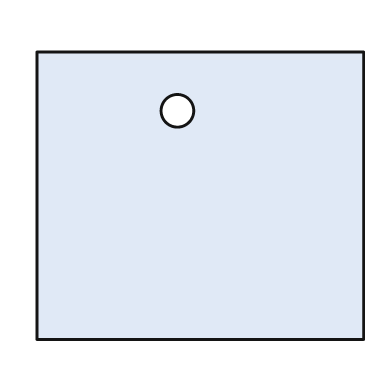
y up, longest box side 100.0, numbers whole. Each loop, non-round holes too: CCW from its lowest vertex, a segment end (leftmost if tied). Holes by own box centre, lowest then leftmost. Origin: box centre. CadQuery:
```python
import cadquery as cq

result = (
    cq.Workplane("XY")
    .moveTo(-50.0, -44.0)
    .lineTo(50.0, -44.0)
    .lineTo(50.0, 44.0)
    .lineTo(-50.0, 44.0)
    .close()
    .moveTo(-7.0, 26.0)
    .circle(5.0)
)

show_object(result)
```